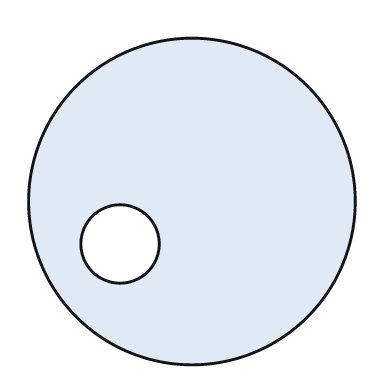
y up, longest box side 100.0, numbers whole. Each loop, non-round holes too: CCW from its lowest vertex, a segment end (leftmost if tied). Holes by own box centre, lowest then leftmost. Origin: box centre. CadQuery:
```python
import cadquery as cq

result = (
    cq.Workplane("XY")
    .moveTo(0.0, 0.0)
    .circle(50.0)
    .moveTo(-22.0, -13.0)
    .circle(12.0)
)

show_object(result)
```